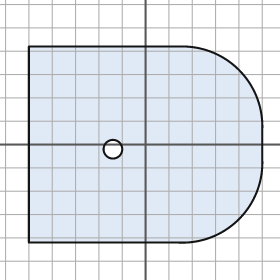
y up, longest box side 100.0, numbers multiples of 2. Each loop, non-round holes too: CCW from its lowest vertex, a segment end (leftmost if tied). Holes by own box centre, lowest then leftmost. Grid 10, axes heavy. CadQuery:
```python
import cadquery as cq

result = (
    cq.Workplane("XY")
    .moveTo(-50.0, -42.0)
    .lineTo(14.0, -42.0)
    .threePointArc((40.0, -32.0), (50.0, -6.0))
    .lineTo(50.0, 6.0)
    .threePointArc((40.0, 32.0), (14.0, 42.0))
    .lineTo(-50.0, 42.0)
    .close()
    .moveTo(-14.0, -2.0)
    .circle(4.0)
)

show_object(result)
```